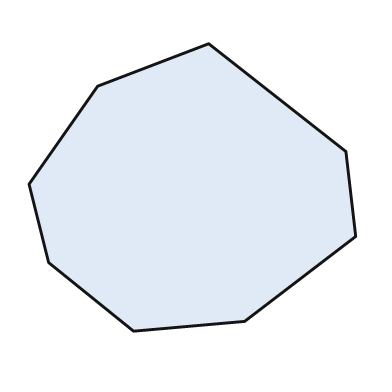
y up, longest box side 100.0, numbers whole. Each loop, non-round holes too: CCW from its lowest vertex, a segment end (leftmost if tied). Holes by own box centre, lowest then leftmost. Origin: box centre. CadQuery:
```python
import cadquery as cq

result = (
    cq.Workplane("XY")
    .moveTo(-18.0, -44.0)
    .lineTo(16.0, -41.0)
    .lineTo(50.0, -15.0)
    .lineTo(47.0, 11.0)
    .lineTo(5.0, 44.0)
    .lineTo(-29.0, 31.0)
    .lineTo(-50.0, 1.0)
    .lineTo(-44.0, -23.0)
    .close()
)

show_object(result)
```